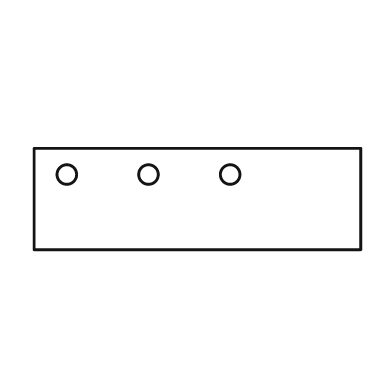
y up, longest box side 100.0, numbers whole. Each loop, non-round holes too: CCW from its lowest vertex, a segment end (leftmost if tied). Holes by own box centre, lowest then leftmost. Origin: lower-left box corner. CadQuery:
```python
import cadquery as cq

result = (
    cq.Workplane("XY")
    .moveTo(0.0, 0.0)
    .lineTo(100.0, 0.0)
    .lineTo(100.0, 31.0)
    .lineTo(0.0, 31.0)
    .close()
    .moveTo(10.0, 23.0)
    .circle(3.0)
    .moveTo(35.0, 23.0)
    .circle(3.0)
    .moveTo(60.0, 23.0)
    .circle(3.0)
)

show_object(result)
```